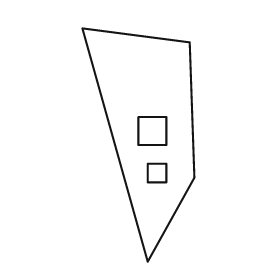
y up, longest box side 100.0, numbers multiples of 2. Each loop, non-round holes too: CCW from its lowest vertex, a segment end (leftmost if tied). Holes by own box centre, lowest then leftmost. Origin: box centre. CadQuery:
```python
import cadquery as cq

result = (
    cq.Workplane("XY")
    .moveTo(4.0, -50.0)
    .lineTo(24.0, -14.0)
    .lineTo(22.0, 44.0)
    .lineTo(-24.0, 50.0)
    .close()
    .moveTo(4.0, -16.0)
    .lineTo(12.0, -16.0)
    .lineTo(12.0, -8.0)
    .lineTo(4.0, -8.0)
    .close()
    .moveTo(0.0, 0.0)
    .lineTo(12.0, 0.0)
    .lineTo(12.0, 12.0)
    .lineTo(0.0, 12.0)
    .close()
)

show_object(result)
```